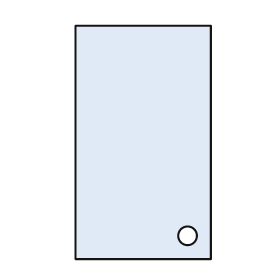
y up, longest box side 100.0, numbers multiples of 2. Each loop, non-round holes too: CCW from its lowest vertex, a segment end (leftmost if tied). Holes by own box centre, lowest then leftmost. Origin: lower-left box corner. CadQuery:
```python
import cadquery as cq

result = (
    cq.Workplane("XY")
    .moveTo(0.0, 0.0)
    .lineTo(58.0, 0.0)
    .lineTo(58.0, 100.0)
    .lineTo(0.0, 100.0)
    .close()
    .moveTo(48.0, 10.0)
    .circle(4.0)
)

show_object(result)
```